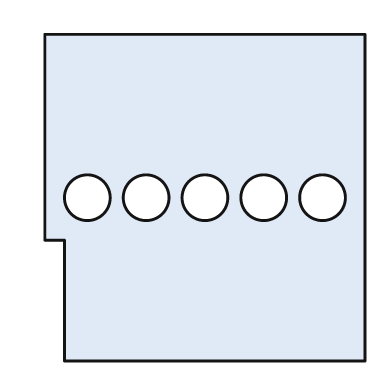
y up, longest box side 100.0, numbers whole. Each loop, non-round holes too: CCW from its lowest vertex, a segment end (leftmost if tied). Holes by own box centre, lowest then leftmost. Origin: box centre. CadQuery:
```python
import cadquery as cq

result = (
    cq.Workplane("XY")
    .moveTo(-43.0, -50.0)
    .lineTo(49.0, -50.0)
    .lineTo(49.0, 50.0)
    .lineTo(-49.0, 50.0)
    .lineTo(-49.0, -13.0)
    .lineTo(-43.0, -13.0)
    .close()
    .moveTo(-36.0, 0.0)
    .circle(7.0)
    .moveTo(-18.0, 0.0)
    .circle(7.0)
    .moveTo(0.0, 0.0)
    .circle(7.0)
    .moveTo(18.0, 0.0)
    .circle(7.0)
    .moveTo(36.0, 0.0)
    .circle(7.0)
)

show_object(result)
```